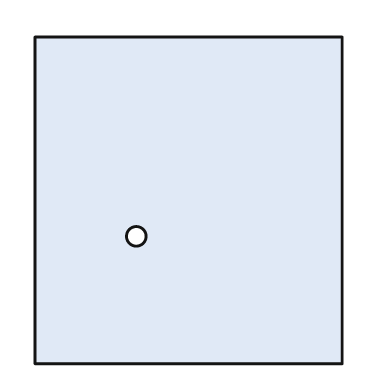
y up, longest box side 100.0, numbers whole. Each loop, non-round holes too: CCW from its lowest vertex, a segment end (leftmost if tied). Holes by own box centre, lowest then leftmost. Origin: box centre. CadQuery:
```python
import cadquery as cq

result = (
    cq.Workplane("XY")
    .moveTo(-47.0, -50.0)
    .lineTo(47.0, -50.0)
    .lineTo(47.0, 50.0)
    .lineTo(-47.0, 50.0)
    .close()
    .moveTo(-16.0, -11.0)
    .circle(3.0)
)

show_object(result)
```